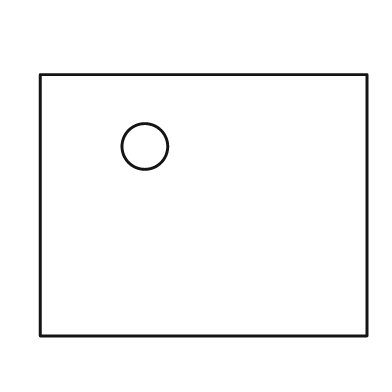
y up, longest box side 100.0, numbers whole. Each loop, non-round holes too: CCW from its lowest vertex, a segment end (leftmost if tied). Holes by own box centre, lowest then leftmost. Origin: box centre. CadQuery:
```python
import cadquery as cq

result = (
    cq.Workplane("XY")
    .moveTo(-50.0, -40.0)
    .lineTo(50.0, -40.0)
    .lineTo(50.0, 40.0)
    .lineTo(-50.0, 40.0)
    .close()
    .moveTo(-18.0, 18.0)
    .circle(7.0)
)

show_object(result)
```